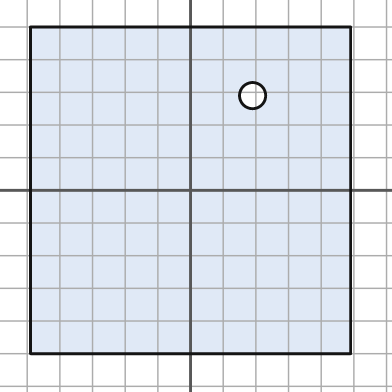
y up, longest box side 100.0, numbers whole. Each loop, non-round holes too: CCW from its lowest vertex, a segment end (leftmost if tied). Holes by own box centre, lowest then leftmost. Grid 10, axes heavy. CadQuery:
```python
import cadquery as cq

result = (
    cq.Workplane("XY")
    .moveTo(-49.0, -50.0)
    .lineTo(49.0, -50.0)
    .lineTo(49.0, 50.0)
    .lineTo(-49.0, 50.0)
    .close()
    .moveTo(19.0, 29.0)
    .circle(4.0)
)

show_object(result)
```